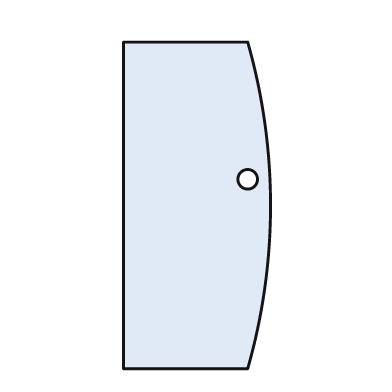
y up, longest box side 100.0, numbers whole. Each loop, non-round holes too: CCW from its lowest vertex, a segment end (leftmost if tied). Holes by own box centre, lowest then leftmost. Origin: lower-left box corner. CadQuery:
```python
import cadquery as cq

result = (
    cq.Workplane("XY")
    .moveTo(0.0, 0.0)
    .lineTo(38.0, 0.0)
    .threePointArc((45.0, 50.0), (38.0, 100.0))
    .lineTo(0.0, 100.0)
    .close()
    .moveTo(38.0, 58.0)
    .circle(3.0)
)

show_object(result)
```